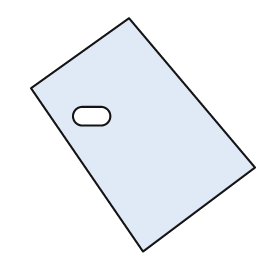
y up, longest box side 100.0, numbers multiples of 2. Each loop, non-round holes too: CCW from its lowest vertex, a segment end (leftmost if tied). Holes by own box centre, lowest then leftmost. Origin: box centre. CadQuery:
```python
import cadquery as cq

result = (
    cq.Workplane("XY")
    .moveTo(0.0, -50.0)
    .lineTo(48.0, -14.0)
    .lineTo(-6.0, 50.0)
    .lineTo(-48.0, 20.0)
    .close()
    .moveTo(-26.0, 4.0)
    .lineTo(-18.0, 4.0)
    .threePointArc((-14.0, 8.0), (-18.0, 12.0))
    .lineTo(-26.0, 12.0)
    .threePointArc((-30.0, 8.0), (-26.0, 4.0))
    .close()
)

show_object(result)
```